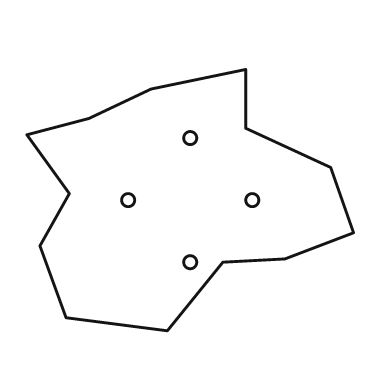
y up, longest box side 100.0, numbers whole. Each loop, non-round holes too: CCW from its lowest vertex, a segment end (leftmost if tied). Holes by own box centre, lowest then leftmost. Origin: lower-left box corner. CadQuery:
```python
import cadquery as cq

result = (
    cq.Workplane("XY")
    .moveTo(43.0, 0.0)
    .lineTo(60.0, 21.0)
    .lineTo(79.0, 22.0)
    .lineTo(100.0, 30.0)
    .lineTo(93.0, 50.0)
    .lineTo(67.0, 62.0)
    .lineTo(67.0, 80.0)
    .lineTo(38.0, 74.0)
    .lineTo(19.0, 65.0)
    .lineTo(0.0, 60.0)
    .lineTo(13.0, 42.0)
    .lineTo(4.0, 26.0)
    .lineTo(12.0, 4.0)
    .close()
    .moveTo(50.0, 21.0)
    .circle(2.0)
    .moveTo(31.0, 40.0)
    .circle(2.0)
    .moveTo(69.0, 40.0)
    .circle(2.0)
    .moveTo(50.0, 59.0)
    .circle(2.0)
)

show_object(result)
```